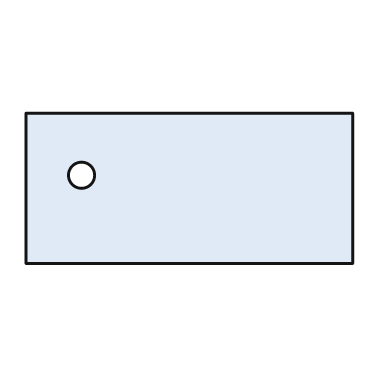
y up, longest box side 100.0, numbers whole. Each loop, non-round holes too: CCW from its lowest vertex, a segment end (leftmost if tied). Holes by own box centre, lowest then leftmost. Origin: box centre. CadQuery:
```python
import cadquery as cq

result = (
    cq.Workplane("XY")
    .moveTo(-50.0, -23.0)
    .lineTo(50.0, -23.0)
    .lineTo(50.0, 23.0)
    .lineTo(-50.0, 23.0)
    .close()
    .moveTo(-33.0, 4.0)
    .circle(4.0)
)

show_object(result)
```